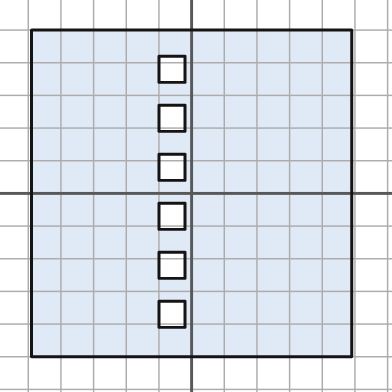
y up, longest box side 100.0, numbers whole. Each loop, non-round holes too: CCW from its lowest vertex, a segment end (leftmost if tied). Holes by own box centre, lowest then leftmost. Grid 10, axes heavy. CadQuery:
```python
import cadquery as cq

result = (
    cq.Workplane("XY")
    .moveTo(-49.0, -50.0)
    .lineTo(49.0, -50.0)
    .lineTo(49.0, 50.0)
    .lineTo(-49.0, 50.0)
    .close()
    .moveTo(-10.0, -41.0)
    .lineTo(-2.0, -41.0)
    .lineTo(-2.0, -33.0)
    .lineTo(-10.0, -33.0)
    .close()
    .moveTo(-10.0, -26.0)
    .lineTo(-2.0, -26.0)
    .lineTo(-2.0, -18.0)
    .lineTo(-10.0, -18.0)
    .close()
    .moveTo(-10.0, -11.0)
    .lineTo(-2.0, -11.0)
    .lineTo(-2.0, -3.0)
    .lineTo(-10.0, -3.0)
    .close()
    .moveTo(-10.0, 4.0)
    .lineTo(-2.0, 4.0)
    .lineTo(-2.0, 12.0)
    .lineTo(-10.0, 12.0)
    .close()
    .moveTo(-10.0, 19.0)
    .lineTo(-2.0, 19.0)
    .lineTo(-2.0, 27.0)
    .lineTo(-10.0, 27.0)
    .close()
    .moveTo(-10.0, 34.0)
    .lineTo(-2.0, 34.0)
    .lineTo(-2.0, 42.0)
    .lineTo(-10.0, 42.0)
    .close()
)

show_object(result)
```